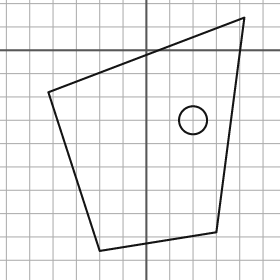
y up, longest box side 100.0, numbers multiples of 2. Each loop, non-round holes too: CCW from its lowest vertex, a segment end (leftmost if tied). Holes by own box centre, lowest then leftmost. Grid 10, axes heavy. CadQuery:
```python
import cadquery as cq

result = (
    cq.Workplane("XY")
    .moveTo(-20.0, -86.0)
    .lineTo(30.0, -78.0)
    .lineTo(42.0, 14.0)
    .lineTo(-42.0, -18.0)
    .close()
    .moveTo(20.0, -30.0)
    .circle(6.0)
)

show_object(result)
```